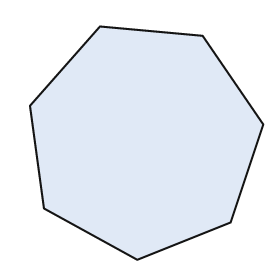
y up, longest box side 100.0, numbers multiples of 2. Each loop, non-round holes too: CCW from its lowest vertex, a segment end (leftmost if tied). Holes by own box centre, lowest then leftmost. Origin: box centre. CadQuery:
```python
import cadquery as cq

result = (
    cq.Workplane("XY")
    .moveTo(-4.0, -50.0)
    .lineTo(36.0, -34.0)
    .lineTo(50.0, 8.0)
    .lineTo(24.0, 46.0)
    .lineTo(-20.0, 50.0)
    .lineTo(-50.0, 16.0)
    .lineTo(-44.0, -28.0)
    .close()
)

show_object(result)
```